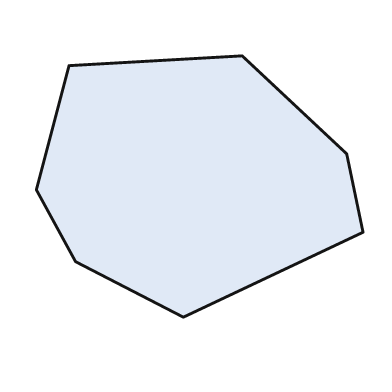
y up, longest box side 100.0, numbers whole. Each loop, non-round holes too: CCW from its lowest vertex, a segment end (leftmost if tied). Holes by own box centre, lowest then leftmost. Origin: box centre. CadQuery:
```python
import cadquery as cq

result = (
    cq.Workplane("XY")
    .moveTo(-5.0, -40.0)
    .lineTo(50.0, -14.0)
    .lineTo(45.0, 10.0)
    .lineTo(13.0, 40.0)
    .lineTo(-40.0, 37.0)
    .lineTo(-50.0, -1.0)
    .lineTo(-38.0, -23.0)
    .close()
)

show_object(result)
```